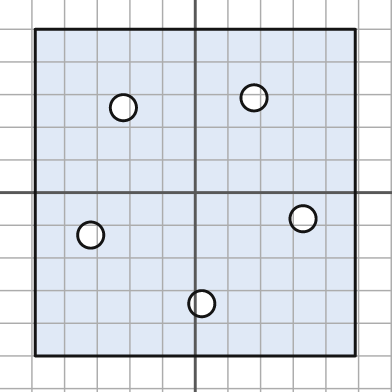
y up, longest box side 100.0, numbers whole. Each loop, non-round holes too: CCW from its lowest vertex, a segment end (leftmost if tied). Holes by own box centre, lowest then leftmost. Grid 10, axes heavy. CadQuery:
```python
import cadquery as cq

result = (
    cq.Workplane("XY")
    .moveTo(-49.0, -50.0)
    .lineTo(49.0, -50.0)
    .lineTo(49.0, 50.0)
    .lineTo(-49.0, 50.0)
    .close()
    .moveTo(2.0, -34.0)
    .circle(4.0)
    .moveTo(-32.0, -13.0)
    .circle(4.0)
    .moveTo(33.0, -8.0)
    .circle(4.0)
    .moveTo(-22.0, 26.0)
    .circle(4.0)
    .moveTo(18.0, 29.0)
    .circle(4.0)
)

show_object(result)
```